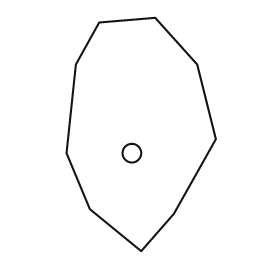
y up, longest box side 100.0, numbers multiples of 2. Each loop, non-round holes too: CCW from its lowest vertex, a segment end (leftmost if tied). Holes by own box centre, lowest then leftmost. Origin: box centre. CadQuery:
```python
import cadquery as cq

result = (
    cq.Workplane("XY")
    .moveTo(0.0, -50.0)
    .lineTo(14.0, -34.0)
    .lineTo(32.0, -2.0)
    .lineTo(24.0, 30.0)
    .lineTo(6.0, 50.0)
    .lineTo(-18.0, 48.0)
    .lineTo(-28.0, 30.0)
    .lineTo(-32.0, -8.0)
    .lineTo(-22.0, -32.0)
    .close()
    .moveTo(-4.0, -8.0)
    .circle(4.0)
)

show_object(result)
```